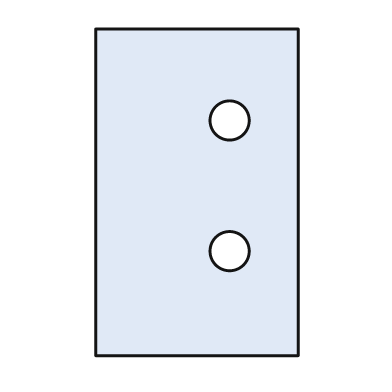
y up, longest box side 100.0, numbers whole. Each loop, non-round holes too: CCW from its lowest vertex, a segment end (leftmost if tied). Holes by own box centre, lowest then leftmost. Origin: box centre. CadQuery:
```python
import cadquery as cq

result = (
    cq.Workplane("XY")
    .moveTo(-31.0, -50.0)
    .lineTo(31.0, -50.0)
    .lineTo(31.0, 50.0)
    .lineTo(-31.0, 50.0)
    .close()
    .moveTo(10.0, -18.0)
    .circle(6.0)
    .moveTo(10.0, 22.0)
    .circle(6.0)
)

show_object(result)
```